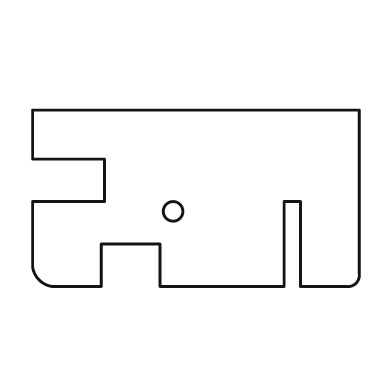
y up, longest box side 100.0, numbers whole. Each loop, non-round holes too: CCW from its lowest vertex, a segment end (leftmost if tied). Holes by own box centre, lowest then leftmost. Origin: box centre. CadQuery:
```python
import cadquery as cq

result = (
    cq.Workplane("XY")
    .moveTo(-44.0, -27.0)
    .lineTo(-29.0, -27.0)
    .lineTo(-29.0, -14.0)
    .lineTo(-11.0, -14.0)
    .lineTo(-11.0, -27.0)
    .lineTo(27.0, -27.0)
    .lineTo(27.0, -1.0)
    .lineTo(32.0, -1.0)
    .lineTo(32.0, -27.0)
    .lineTo(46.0, -27.0)
    .threePointArc((49.0, -26.0), (50.0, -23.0))
    .lineTo(50.0, 27.0)
    .lineTo(-50.0, 27.0)
    .lineTo(-50.0, 12.0)
    .lineTo(-28.0, 12.0)
    .lineTo(-28.0, -1.0)
    .lineTo(-50.0, -1.0)
    .lineTo(-50.0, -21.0)
    .threePointArc((-48.0, -25.0), (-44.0, -27.0))
    .close()
    .moveTo(-7.0, -4.0)
    .circle(3.0)
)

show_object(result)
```